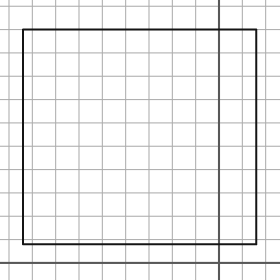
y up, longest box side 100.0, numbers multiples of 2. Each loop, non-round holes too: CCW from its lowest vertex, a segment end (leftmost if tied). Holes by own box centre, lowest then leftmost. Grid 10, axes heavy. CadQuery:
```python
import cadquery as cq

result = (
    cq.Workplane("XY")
    .moveTo(-84.0, 8.0)
    .lineTo(16.0, 8.0)
    .lineTo(16.0, 100.0)
    .lineTo(-84.0, 100.0)
    .close()
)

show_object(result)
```